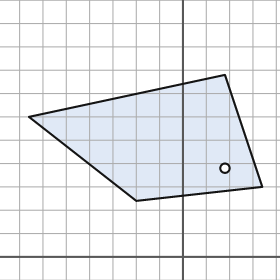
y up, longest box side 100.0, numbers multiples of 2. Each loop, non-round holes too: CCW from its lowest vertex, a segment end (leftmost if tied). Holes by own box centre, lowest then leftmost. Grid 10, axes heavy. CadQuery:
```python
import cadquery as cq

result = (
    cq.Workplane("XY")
    .moveTo(-20.0, 24.0)
    .lineTo(34.0, 30.0)
    .lineTo(18.0, 78.0)
    .lineTo(-66.0, 60.0)
    .close()
    .moveTo(18.0, 38.0)
    .circle(2.0)
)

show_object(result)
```